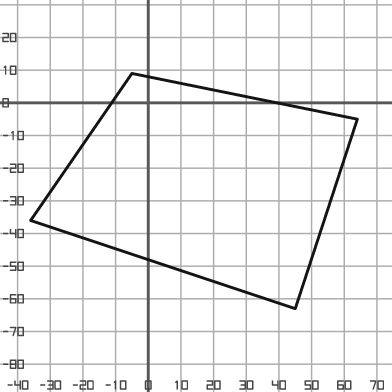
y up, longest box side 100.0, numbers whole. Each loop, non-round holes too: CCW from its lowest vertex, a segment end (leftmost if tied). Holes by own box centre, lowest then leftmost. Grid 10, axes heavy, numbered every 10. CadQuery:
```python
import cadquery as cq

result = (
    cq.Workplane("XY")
    .moveTo(45.0, -63.0)
    .lineTo(64.0, -5.0)
    .lineTo(-5.0, 9.0)
    .lineTo(-36.0, -36.0)
    .close()
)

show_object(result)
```